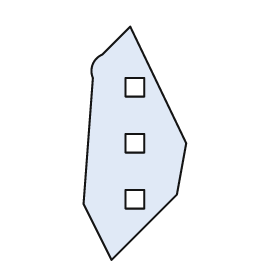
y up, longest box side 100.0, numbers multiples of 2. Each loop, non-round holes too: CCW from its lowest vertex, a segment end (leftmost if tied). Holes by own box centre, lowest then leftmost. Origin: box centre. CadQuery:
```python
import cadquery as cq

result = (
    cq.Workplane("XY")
    .moveTo(-10.0, -50.0)
    .lineTo(18.0, -22.0)
    .lineTo(22.0, 0.0)
    .lineTo(-2.0, 50.0)
    .lineTo(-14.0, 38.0)
    .threePointArc((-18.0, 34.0), (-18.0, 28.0))
    .lineTo(-22.0, -26.0)
    .close()
    .moveTo(-4.0, -28.0)
    .lineTo(4.0, -28.0)
    .lineTo(4.0, -20.0)
    .lineTo(-4.0, -20.0)
    .close()
    .moveTo(-4.0, -4.0)
    .lineTo(4.0, -4.0)
    .lineTo(4.0, 4.0)
    .lineTo(-4.0, 4.0)
    .close()
    .moveTo(-4.0, 20.0)
    .lineTo(4.0, 20.0)
    .lineTo(4.0, 28.0)
    .lineTo(-4.0, 28.0)
    .close()
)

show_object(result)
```